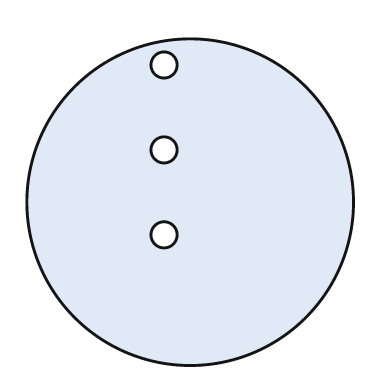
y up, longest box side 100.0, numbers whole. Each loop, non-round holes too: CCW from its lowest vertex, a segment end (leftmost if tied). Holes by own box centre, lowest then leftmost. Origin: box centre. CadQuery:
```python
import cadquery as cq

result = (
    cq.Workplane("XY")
    .moveTo(0.0, 0.0)
    .circle(50.0)
    .moveTo(-8.0, -10.0)
    .circle(4.0)
    .moveTo(-8.0, 16.0)
    .circle(4.0)
    .moveTo(-8.0, 42.0)
    .circle(4.0)
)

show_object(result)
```